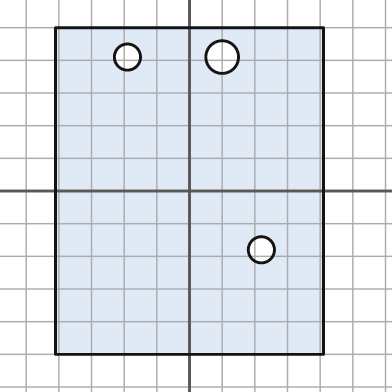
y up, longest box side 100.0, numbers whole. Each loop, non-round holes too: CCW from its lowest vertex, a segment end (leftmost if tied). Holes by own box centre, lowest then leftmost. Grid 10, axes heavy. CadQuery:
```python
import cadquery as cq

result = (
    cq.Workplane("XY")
    .moveTo(-41.0, -50.0)
    .lineTo(41.0, -50.0)
    .lineTo(41.0, 50.0)
    .lineTo(-41.0, 50.0)
    .close()
    .moveTo(22.0, -18.0)
    .circle(4.0)
    .moveTo(-19.0, 41.0)
    .circle(4.0)
    .moveTo(10.0, 41.0)
    .circle(5.0)
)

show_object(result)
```